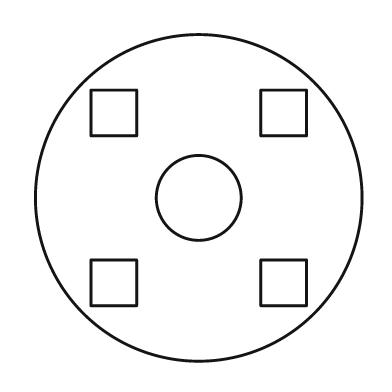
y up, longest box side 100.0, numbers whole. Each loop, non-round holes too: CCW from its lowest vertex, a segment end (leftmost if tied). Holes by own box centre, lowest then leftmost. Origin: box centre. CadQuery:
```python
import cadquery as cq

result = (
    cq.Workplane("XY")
    .moveTo(0.0, 0.0)
    .circle(50.0)
    .moveTo(-33.0, -33.0)
    .lineTo(-19.0, -33.0)
    .lineTo(-19.0, -19.0)
    .lineTo(-33.0, -19.0)
    .close()
    .moveTo(19.0, -33.0)
    .lineTo(33.0, -33.0)
    .lineTo(33.0, -19.0)
    .lineTo(19.0, -19.0)
    .close()
    .moveTo(0.0, 0.0)
    .circle(13.0)
    .moveTo(-33.0, 19.0)
    .lineTo(-19.0, 19.0)
    .lineTo(-19.0, 33.0)
    .lineTo(-33.0, 33.0)
    .close()
    .moveTo(19.0, 19.0)
    .lineTo(33.0, 19.0)
    .lineTo(33.0, 33.0)
    .lineTo(19.0, 33.0)
    .close()
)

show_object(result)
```